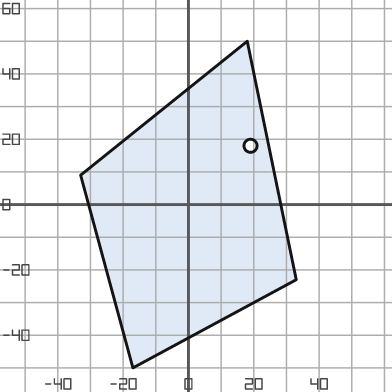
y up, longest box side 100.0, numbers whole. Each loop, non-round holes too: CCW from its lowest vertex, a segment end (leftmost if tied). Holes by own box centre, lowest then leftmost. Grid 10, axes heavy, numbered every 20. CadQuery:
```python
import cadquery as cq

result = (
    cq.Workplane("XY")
    .moveTo(-17.0, -50.0)
    .lineTo(33.0, -23.0)
    .lineTo(18.0, 50.0)
    .lineTo(-33.0, 9.0)
    .close()
    .moveTo(19.0, 18.0)
    .circle(2.0)
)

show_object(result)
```